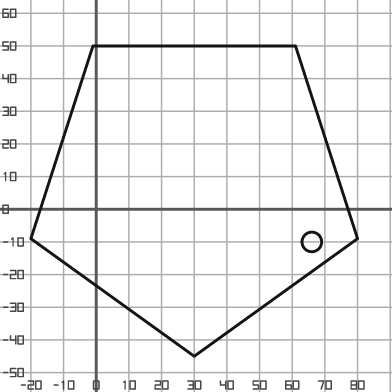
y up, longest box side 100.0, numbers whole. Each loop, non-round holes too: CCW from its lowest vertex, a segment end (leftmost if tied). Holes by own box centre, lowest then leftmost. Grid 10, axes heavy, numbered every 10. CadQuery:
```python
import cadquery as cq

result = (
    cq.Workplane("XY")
    .moveTo(30.0, -45.0)
    .lineTo(80.0, -9.0)
    .lineTo(61.0, 50.0)
    .lineTo(-1.0, 50.0)
    .lineTo(-20.0, -9.0)
    .close()
    .moveTo(66.0, -10.0)
    .circle(3.0)
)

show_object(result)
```